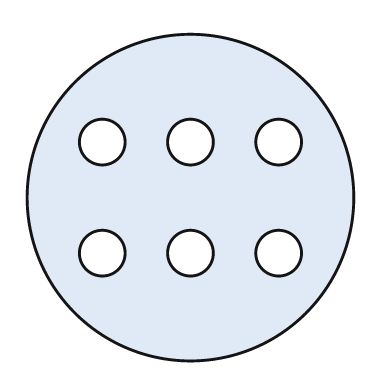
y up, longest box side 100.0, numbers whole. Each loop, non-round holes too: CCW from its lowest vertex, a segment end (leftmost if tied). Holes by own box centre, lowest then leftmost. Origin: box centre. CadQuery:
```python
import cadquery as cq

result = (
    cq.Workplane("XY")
    .moveTo(0.0, 0.0)
    .circle(50.0)
    .moveTo(-27.0, -17.0)
    .circle(7.0)
    .moveTo(0.0, -17.0)
    .circle(7.0)
    .moveTo(27.0, -17.0)
    .circle(7.0)
    .moveTo(-27.0, 17.0)
    .circle(7.0)
    .moveTo(0.0, 17.0)
    .circle(7.0)
    .moveTo(27.0, 17.0)
    .circle(7.0)
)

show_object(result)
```